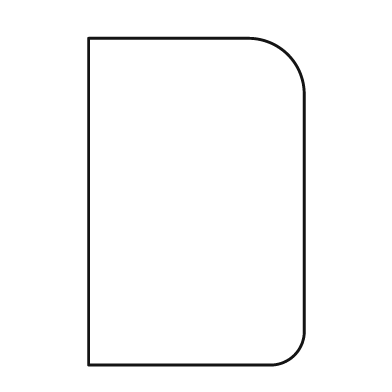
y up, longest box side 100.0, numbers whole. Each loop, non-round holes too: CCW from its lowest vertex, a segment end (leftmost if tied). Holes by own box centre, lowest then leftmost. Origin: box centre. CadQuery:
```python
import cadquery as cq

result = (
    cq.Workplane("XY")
    .moveTo(-33.0, -50.0)
    .lineTo(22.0, -50.0)
    .threePointArc((30.0, -47.0), (33.0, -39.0))
    .lineTo(33.0, 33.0)
    .threePointArc((28.0, 45.0), (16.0, 50.0))
    .lineTo(-33.0, 50.0)
    .close()
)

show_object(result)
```